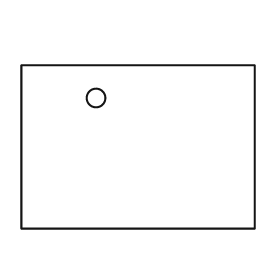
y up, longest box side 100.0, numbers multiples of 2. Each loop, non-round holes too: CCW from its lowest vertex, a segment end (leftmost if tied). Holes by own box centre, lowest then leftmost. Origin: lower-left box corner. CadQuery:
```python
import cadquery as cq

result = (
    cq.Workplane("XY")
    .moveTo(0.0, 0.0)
    .lineTo(100.0, 0.0)
    .lineTo(100.0, 70.0)
    .lineTo(0.0, 70.0)
    .close()
    .moveTo(32.0, 56.0)
    .circle(4.0)
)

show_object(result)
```